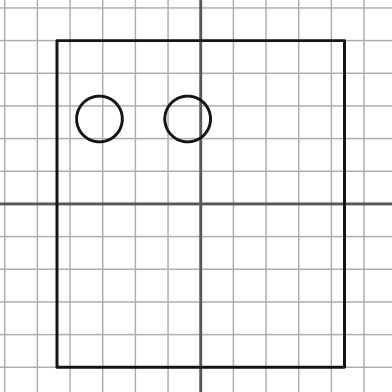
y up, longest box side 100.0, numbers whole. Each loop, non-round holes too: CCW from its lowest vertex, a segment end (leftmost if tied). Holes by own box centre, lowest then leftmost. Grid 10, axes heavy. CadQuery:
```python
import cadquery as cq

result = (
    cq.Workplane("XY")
    .moveTo(-44.0, -50.0)
    .lineTo(44.0, -50.0)
    .lineTo(44.0, 50.0)
    .lineTo(-44.0, 50.0)
    .close()
    .moveTo(-31.0, 26.0)
    .circle(7.0)
    .moveTo(-4.0, 26.0)
    .circle(7.0)
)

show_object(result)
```